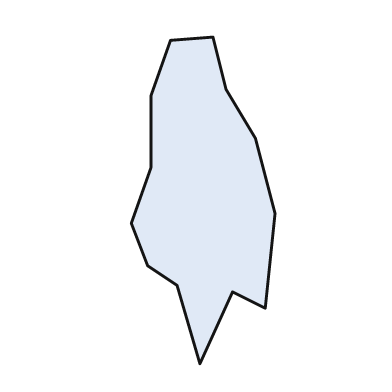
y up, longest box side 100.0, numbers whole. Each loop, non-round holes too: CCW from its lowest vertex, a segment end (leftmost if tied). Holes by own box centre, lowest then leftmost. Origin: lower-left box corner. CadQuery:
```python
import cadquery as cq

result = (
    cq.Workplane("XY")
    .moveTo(21.0, 0.0)
    .lineTo(31.0, 22.0)
    .lineTo(41.0, 17.0)
    .lineTo(44.0, 46.0)
    .lineTo(38.0, 69.0)
    .lineTo(29.0, 84.0)
    .lineTo(25.0, 100.0)
    .lineTo(12.0, 99.0)
    .lineTo(6.0, 82.0)
    .lineTo(6.0, 60.0)
    .lineTo(0.0, 43.0)
    .lineTo(5.0, 30.0)
    .lineTo(14.0, 24.0)
    .close()
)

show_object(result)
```